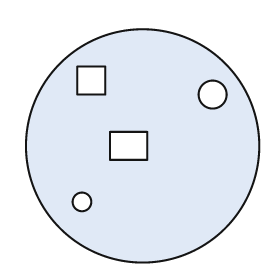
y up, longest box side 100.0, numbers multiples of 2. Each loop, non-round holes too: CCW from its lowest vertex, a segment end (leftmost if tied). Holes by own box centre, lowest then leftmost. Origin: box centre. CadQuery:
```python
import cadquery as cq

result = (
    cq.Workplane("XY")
    .moveTo(0.0, 0.0)
    .circle(50.0)
    .moveTo(-26.0, -24.0)
    .circle(4.0)
    .moveTo(-14.0, -6.0)
    .lineTo(2.0, -6.0)
    .lineTo(2.0, 6.0)
    .lineTo(-14.0, 6.0)
    .close()
    .moveTo(30.0, 22.0)
    .circle(6.0)
    .moveTo(-28.0, 22.0)
    .lineTo(-16.0, 22.0)
    .lineTo(-16.0, 34.0)
    .lineTo(-28.0, 34.0)
    .close()
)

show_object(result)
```